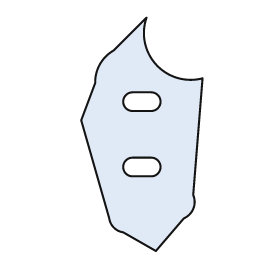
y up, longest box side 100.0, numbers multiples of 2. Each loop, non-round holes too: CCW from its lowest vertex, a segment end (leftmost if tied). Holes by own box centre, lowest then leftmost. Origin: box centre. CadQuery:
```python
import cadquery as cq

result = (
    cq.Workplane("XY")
    .moveTo(6.0, -50.0)
    .lineTo(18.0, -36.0)
    .threePointArc((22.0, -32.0), (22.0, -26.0))
    .lineTo(26.0, 24.0)
    .threePointArc((6.0, 30.0), (2.0, 50.0))
    .lineTo(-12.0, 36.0)
    .threePointArc((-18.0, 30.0), (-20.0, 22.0))
    .lineTo(-26.0, 6.0)
    .lineTo(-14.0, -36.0)
    .threePointArc((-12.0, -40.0), (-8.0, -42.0))
    .close()
    .moveTo(-4.0, -18.0)
    .lineTo(4.0, -18.0)
    .threePointArc((8.0, -14.0), (4.0, -10.0))
    .lineTo(-4.0, -10.0)
    .threePointArc((-8.0, -14.0), (-4.0, -18.0))
    .close()
    .moveTo(-4.0, 10.0)
    .lineTo(4.0, 10.0)
    .threePointArc((8.0, 14.0), (4.0, 18.0))
    .lineTo(-4.0, 18.0)
    .threePointArc((-8.0, 14.0), (-4.0, 10.0))
    .close()
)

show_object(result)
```